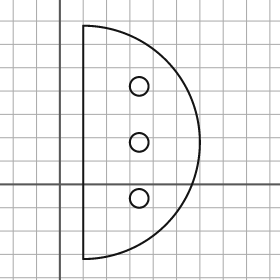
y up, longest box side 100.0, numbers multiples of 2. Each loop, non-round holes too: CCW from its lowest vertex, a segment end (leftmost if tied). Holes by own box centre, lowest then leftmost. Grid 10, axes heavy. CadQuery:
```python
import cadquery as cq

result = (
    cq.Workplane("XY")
    .moveTo(10.0, -32.0)
    .threePointArc((60.0, 18.0), (10.0, 68.0))
    .close()
    .moveTo(34.0, -6.0)
    .circle(4.0)
    .moveTo(34.0, 18.0)
    .circle(4.0)
    .moveTo(34.0, 42.0)
    .circle(4.0)
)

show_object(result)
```